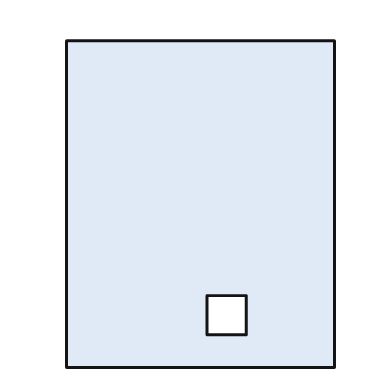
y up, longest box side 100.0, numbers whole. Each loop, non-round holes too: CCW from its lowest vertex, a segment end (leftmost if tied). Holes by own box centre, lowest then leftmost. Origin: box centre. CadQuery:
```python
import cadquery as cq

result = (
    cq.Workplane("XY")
    .moveTo(-41.0, -50.0)
    .lineTo(41.0, -50.0)
    .lineTo(41.0, 50.0)
    .lineTo(-41.0, 50.0)
    .close()
    .moveTo(2.0, -40.0)
    .lineTo(14.0, -40.0)
    .lineTo(14.0, -28.0)
    .lineTo(2.0, -28.0)
    .close()
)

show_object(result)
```